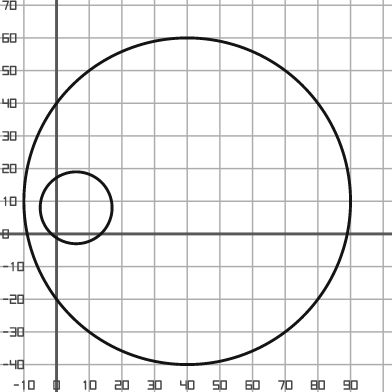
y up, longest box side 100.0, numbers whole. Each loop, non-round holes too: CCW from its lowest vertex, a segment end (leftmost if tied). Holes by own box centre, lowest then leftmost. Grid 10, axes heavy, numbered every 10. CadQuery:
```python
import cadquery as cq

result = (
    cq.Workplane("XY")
    .moveTo(40.0, 10.0)
    .circle(50.0)
    .moveTo(6.0, 8.0)
    .circle(11.0)
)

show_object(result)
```